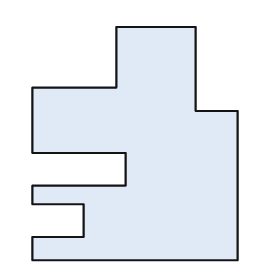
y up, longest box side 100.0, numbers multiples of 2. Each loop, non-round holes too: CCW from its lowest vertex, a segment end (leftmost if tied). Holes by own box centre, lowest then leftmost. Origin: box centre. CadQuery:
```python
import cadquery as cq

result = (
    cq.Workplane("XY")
    .moveTo(-44.0, -50.0)
    .lineTo(44.0, -50.0)
    .lineTo(44.0, 14.0)
    .lineTo(26.0, 14.0)
    .lineTo(26.0, 50.0)
    .lineTo(-8.0, 50.0)
    .lineTo(-8.0, 24.0)
    .lineTo(-44.0, 24.0)
    .lineTo(-44.0, -4.0)
    .lineTo(-4.0, -4.0)
    .lineTo(-4.0, -18.0)
    .lineTo(-44.0, -18.0)
    .lineTo(-44.0, -26.0)
    .lineTo(-22.0, -26.0)
    .lineTo(-22.0, -40.0)
    .lineTo(-44.0, -40.0)
    .close()
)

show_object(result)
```